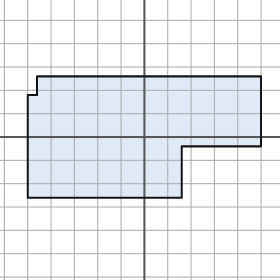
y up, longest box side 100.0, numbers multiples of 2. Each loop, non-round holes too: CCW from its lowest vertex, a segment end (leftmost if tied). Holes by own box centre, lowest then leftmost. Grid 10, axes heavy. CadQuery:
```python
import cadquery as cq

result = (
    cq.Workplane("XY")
    .moveTo(-50.0, -26.0)
    .lineTo(16.0, -26.0)
    .lineTo(16.0, -4.0)
    .lineTo(50.0, -4.0)
    .lineTo(50.0, 26.0)
    .lineTo(-46.0, 26.0)
    .lineTo(-46.0, 18.0)
    .lineTo(-50.0, 18.0)
    .close()
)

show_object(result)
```